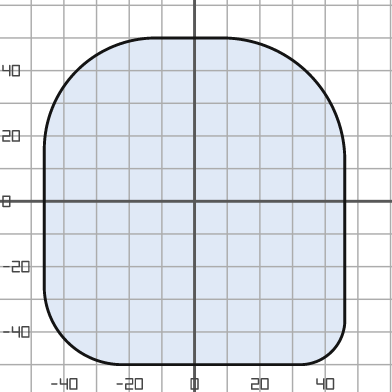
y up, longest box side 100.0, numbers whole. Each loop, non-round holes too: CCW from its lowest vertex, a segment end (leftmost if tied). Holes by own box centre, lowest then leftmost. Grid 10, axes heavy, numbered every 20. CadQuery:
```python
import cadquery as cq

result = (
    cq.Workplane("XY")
    .moveTo(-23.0, -50.0)
    .lineTo(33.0, -50.0)
    .threePointArc((42.0, -46.0), (46.0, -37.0))
    .lineTo(46.0, 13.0)
    .threePointArc((35.0, 39.0), (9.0, 50.0))
    .lineTo(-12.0, 50.0)
    .threePointArc((-36.0, 40.0), (-46.0, 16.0))
    .lineTo(-46.0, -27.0)
    .threePointArc((-39.0, -43.0), (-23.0, -50.0))
    .close()
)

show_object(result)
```